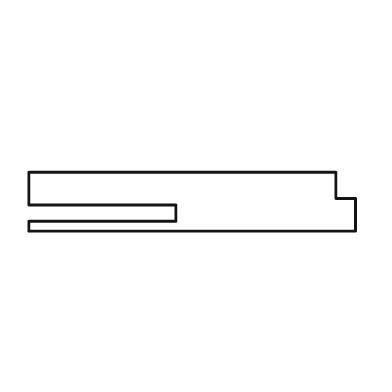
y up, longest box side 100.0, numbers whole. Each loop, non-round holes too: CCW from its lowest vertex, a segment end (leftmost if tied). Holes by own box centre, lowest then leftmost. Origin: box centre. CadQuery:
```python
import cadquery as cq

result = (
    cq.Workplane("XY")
    .moveTo(-50.0, -9.0)
    .lineTo(50.0, -9.0)
    .lineTo(50.0, 1.0)
    .lineTo(44.0, 1.0)
    .lineTo(44.0, 9.0)
    .lineTo(-50.0, 9.0)
    .lineTo(-50.0, -1.0)
    .lineTo(-5.0, -1.0)
    .lineTo(-5.0, -6.0)
    .lineTo(-50.0, -6.0)
    .close()
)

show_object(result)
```